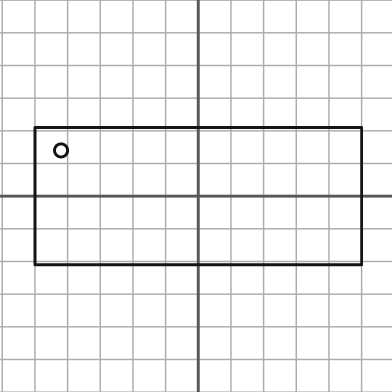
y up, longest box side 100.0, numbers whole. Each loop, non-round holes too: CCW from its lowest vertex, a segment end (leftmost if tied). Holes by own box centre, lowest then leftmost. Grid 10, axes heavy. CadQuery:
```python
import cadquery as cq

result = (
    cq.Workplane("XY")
    .moveTo(-50.0, -21.0)
    .lineTo(50.0, -21.0)
    .lineTo(50.0, 21.0)
    .lineTo(-50.0, 21.0)
    .close()
    .moveTo(-42.0, 14.0)
    .circle(2.0)
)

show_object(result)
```